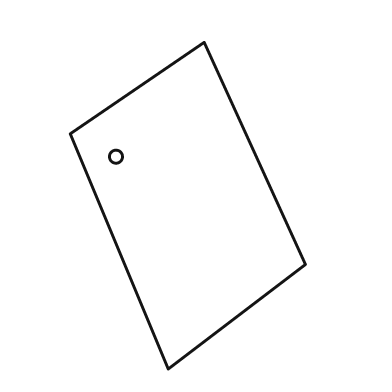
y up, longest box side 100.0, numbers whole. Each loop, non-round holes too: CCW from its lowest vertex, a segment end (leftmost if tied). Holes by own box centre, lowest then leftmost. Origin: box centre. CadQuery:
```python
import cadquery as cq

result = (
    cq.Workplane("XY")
    .moveTo(-6.0, -50.0)
    .lineTo(36.0, -18.0)
    .lineTo(5.0, 50.0)
    .lineTo(-36.0, 22.0)
    .close()
    .moveTo(-22.0, 15.0)
    .circle(2.0)
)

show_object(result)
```